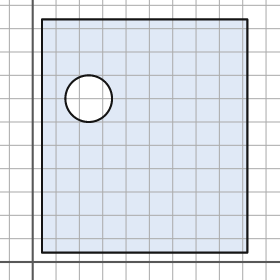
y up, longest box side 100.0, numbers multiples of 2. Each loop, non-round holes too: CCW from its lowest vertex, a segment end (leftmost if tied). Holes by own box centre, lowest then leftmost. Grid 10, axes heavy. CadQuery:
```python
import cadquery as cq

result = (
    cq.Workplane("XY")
    .moveTo(4.0, 4.0)
    .lineTo(92.0, 4.0)
    .lineTo(92.0, 104.0)
    .lineTo(4.0, 104.0)
    .close()
    .moveTo(24.0, 70.0)
    .circle(10.0)
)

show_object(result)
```